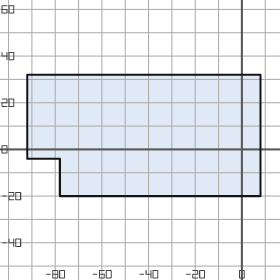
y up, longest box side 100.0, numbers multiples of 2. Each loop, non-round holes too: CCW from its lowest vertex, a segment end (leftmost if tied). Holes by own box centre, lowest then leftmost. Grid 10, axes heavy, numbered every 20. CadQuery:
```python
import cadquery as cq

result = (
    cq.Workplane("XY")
    .moveTo(-78.0, -20.0)
    .lineTo(8.0, -20.0)
    .lineTo(8.0, 32.0)
    .lineTo(-92.0, 32.0)
    .lineTo(-92.0, -4.0)
    .lineTo(-78.0, -4.0)
    .close()
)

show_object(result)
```